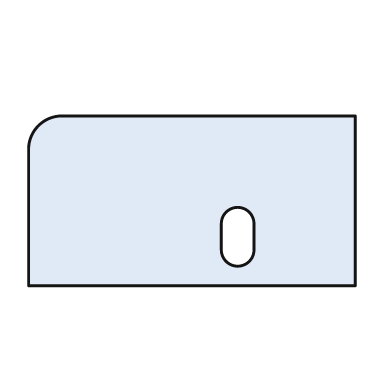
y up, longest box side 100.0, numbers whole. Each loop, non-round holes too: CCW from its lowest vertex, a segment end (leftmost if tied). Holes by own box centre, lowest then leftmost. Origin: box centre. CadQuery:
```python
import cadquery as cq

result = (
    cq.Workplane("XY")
    .moveTo(-50.0, -26.0)
    .lineTo(50.0, -26.0)
    .lineTo(50.0, 26.0)
    .lineTo(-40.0, 26.0)
    .threePointArc((-47.0, 23.0), (-50.0, 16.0))
    .close()
    .moveTo(9.0, -15.0)
    .threePointArc((14.0, -20.0), (19.0, -15.0))
    .lineTo(19.0, -7.0)
    .threePointArc((14.0, -2.0), (9.0, -7.0))
    .close()
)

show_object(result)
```